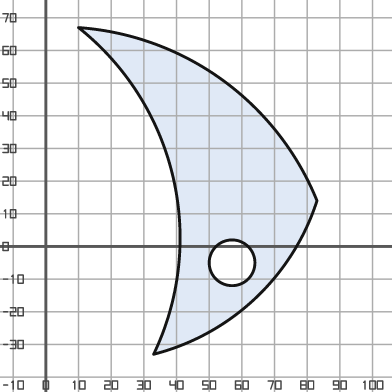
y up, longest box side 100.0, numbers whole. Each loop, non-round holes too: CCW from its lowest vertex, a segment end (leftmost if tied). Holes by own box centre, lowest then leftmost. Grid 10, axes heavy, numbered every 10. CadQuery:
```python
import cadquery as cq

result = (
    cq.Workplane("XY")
    .moveTo(33.0, -33.0)
    .threePointArc((64.0, -16.0), (83.0, 14.0))
    .threePointArc((54.0, 51.0), (10.0, 67.0))
    .threePointArc((39.0, 21.0), (33.0, -33.0))
    .close()
    .moveTo(57.0, -5.0)
    .circle(7.0)
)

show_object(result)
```